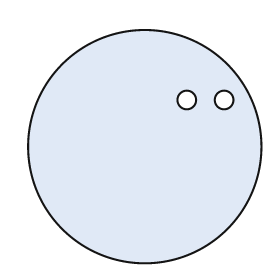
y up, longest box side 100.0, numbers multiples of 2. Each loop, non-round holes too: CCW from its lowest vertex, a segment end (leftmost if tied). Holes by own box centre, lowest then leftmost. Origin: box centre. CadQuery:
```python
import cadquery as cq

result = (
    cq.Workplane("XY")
    .moveTo(0.0, 0.0)
    .circle(50.0)
    .moveTo(18.0, 20.0)
    .circle(4.0)
    .moveTo(34.0, 20.0)
    .circle(4.0)
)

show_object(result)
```